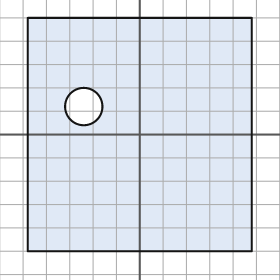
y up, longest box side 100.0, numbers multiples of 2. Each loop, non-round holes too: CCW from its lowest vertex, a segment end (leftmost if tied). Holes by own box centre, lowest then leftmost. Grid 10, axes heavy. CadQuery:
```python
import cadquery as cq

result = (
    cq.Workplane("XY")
    .moveTo(-48.0, -50.0)
    .lineTo(48.0, -50.0)
    .lineTo(48.0, 50.0)
    .lineTo(-48.0, 50.0)
    .close()
    .moveTo(-24.0, 12.0)
    .circle(8.0)
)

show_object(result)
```